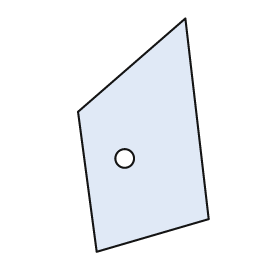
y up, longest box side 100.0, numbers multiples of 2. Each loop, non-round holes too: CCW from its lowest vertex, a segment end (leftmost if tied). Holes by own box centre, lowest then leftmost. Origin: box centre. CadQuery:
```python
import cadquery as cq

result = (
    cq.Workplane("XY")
    .moveTo(-20.0, -50.0)
    .lineTo(28.0, -36.0)
    .lineTo(18.0, 50.0)
    .lineTo(-28.0, 10.0)
    .close()
    .moveTo(-8.0, -10.0)
    .circle(4.0)
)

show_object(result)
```